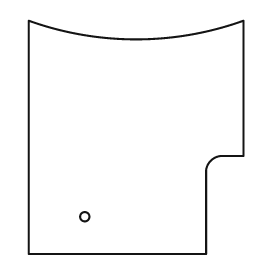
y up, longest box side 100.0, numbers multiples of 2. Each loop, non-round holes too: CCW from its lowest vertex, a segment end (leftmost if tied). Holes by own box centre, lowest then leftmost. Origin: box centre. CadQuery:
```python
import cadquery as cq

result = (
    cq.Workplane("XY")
    .moveTo(-46.0, -50.0)
    .lineTo(30.0, -50.0)
    .lineTo(30.0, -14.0)
    .threePointArc((32.0, -10.0), (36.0, -8.0))
    .lineTo(46.0, -8.0)
    .lineTo(46.0, 50.0)
    .threePointArc((0.0, 42.0), (-46.0, 50.0))
    .close()
    .moveTo(-22.0, -34.0)
    .circle(2.0)
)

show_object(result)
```